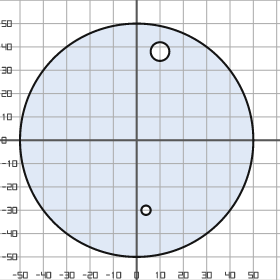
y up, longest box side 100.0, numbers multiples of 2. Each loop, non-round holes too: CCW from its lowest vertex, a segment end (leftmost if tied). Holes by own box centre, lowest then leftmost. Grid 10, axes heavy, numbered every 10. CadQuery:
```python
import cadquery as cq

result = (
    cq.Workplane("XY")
    .moveTo(0.0, 0.0)
    .circle(50.0)
    .moveTo(4.0, -30.0)
    .circle(2.0)
    .moveTo(10.0, 38.0)
    .circle(4.0)
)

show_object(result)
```